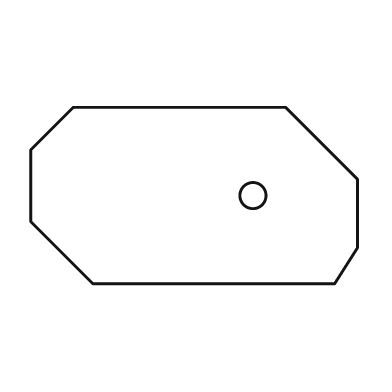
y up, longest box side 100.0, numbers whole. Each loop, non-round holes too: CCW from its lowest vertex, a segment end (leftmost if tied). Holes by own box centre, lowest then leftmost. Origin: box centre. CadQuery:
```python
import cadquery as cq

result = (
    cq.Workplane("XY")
    .moveTo(-31.0, -27.0)
    .lineTo(43.0, -27.0)
    .lineTo(50.0, -16.0)
    .lineTo(50.0, 5.0)
    .lineTo(28.0, 27.0)
    .lineTo(-37.0, 27.0)
    .lineTo(-50.0, 14.0)
    .lineTo(-50.0, -8.0)
    .close()
    .moveTo(18.0, 0.0)
    .circle(4.0)
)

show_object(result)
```